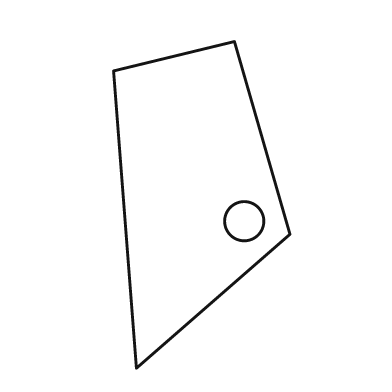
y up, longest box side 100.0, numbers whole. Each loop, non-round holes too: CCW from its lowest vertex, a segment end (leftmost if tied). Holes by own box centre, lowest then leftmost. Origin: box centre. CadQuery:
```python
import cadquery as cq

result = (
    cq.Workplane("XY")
    .moveTo(-20.0, -50.0)
    .lineTo(27.0, -9.0)
    .lineTo(10.0, 50.0)
    .lineTo(-27.0, 41.0)
    .close()
    .moveTo(13.0, -5.0)
    .circle(6.0)
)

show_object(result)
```